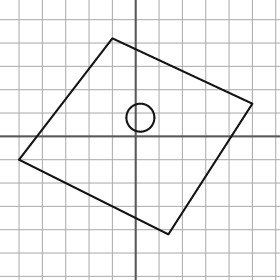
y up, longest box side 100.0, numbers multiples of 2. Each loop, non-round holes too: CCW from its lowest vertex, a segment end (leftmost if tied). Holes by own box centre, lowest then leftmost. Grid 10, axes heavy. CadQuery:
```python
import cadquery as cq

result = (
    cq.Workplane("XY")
    .moveTo(14.0, -42.0)
    .lineTo(50.0, 14.0)
    .lineTo(-10.0, 42.0)
    .lineTo(-50.0, -10.0)
    .close()
    .moveTo(2.0, 8.0)
    .circle(6.0)
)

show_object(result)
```